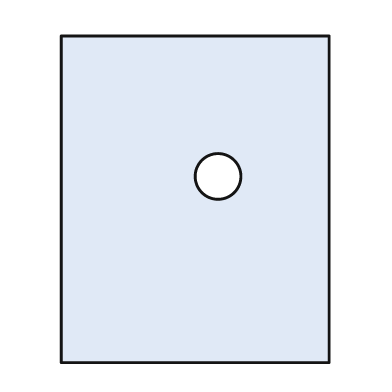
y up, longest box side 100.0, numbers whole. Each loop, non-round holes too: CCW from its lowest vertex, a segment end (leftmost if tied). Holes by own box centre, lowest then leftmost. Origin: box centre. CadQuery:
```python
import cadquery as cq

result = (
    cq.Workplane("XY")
    .moveTo(-41.0, -50.0)
    .lineTo(41.0, -50.0)
    .lineTo(41.0, 50.0)
    .lineTo(-41.0, 50.0)
    .close()
    .moveTo(7.0, 7.0)
    .circle(7.0)
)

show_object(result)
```